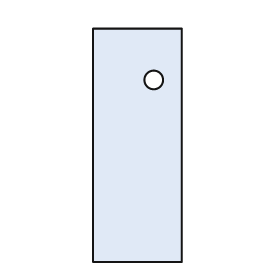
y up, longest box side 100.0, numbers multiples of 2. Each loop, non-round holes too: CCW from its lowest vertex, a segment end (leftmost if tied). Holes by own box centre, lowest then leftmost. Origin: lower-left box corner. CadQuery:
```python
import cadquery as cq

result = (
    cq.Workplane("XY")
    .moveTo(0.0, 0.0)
    .lineTo(38.0, 0.0)
    .lineTo(38.0, 100.0)
    .lineTo(0.0, 100.0)
    .close()
    .moveTo(26.0, 78.0)
    .circle(4.0)
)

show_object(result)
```